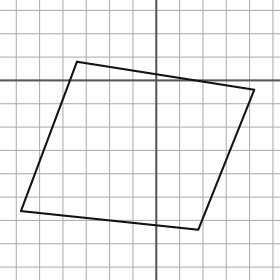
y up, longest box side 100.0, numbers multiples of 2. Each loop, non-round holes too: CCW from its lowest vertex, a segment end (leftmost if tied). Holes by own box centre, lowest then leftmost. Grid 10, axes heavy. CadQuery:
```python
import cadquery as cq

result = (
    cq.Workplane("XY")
    .moveTo(18.0, -64.0)
    .lineTo(42.0, -4.0)
    .lineTo(-34.0, 8.0)
    .lineTo(-58.0, -56.0)
    .close()
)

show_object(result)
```